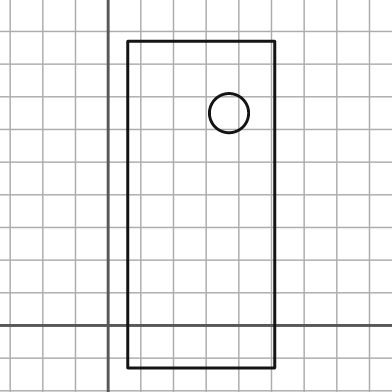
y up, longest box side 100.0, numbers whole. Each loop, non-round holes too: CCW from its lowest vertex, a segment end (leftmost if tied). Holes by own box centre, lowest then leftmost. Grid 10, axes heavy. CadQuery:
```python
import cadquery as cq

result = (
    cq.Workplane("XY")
    .moveTo(6.0, -13.0)
    .lineTo(51.0, -13.0)
    .lineTo(51.0, 87.0)
    .lineTo(6.0, 87.0)
    .close()
    .moveTo(37.0, 65.0)
    .circle(6.0)
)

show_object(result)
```